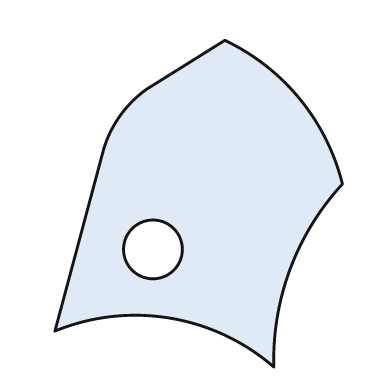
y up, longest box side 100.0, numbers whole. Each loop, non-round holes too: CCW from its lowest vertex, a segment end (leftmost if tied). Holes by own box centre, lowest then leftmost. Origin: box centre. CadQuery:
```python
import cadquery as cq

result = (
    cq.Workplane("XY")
    .moveTo(23.0, -50.0)
    .threePointArc((28.0, -20.0), (44.0, 6.0))
    .threePointArc((31.0, 32.0), (8.0, 50.0))
    .lineTo(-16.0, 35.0)
    .threePointArc((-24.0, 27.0), (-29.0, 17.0))
    .lineTo(-44.0, -39.0)
    .threePointArc((-9.0, -35.0), (23.0, -50.0))
    .close()
    .moveTo(-14.0, -14.0)
    .circle(9.0)
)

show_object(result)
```